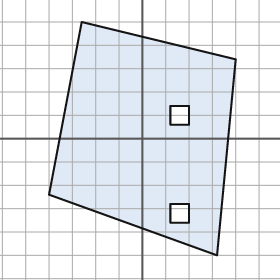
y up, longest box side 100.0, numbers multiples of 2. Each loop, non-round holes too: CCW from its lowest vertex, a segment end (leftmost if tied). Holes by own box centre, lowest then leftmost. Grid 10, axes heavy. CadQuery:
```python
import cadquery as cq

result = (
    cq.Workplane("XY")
    .moveTo(32.0, -50.0)
    .lineTo(40.0, 34.0)
    .lineTo(-26.0, 50.0)
    .lineTo(-40.0, -24.0)
    .close()
    .moveTo(12.0, -36.0)
    .lineTo(20.0, -36.0)
    .lineTo(20.0, -28.0)
    .lineTo(12.0, -28.0)
    .close()
    .moveTo(12.0, 6.0)
    .lineTo(20.0, 6.0)
    .lineTo(20.0, 14.0)
    .lineTo(12.0, 14.0)
    .close()
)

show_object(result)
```